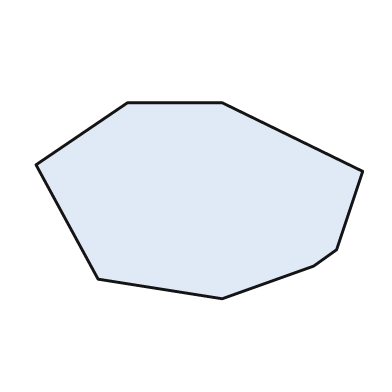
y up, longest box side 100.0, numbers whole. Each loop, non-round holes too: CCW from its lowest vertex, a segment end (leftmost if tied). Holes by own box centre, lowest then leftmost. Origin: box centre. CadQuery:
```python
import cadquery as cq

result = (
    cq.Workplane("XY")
    .moveTo(7.0, -30.0)
    .lineTo(35.0, -20.0)
    .lineTo(42.0, -15.0)
    .lineTo(50.0, 9.0)
    .lineTo(7.0, 30.0)
    .lineTo(-22.0, 30.0)
    .lineTo(-50.0, 11.0)
    .lineTo(-31.0, -24.0)
    .close()
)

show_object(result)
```